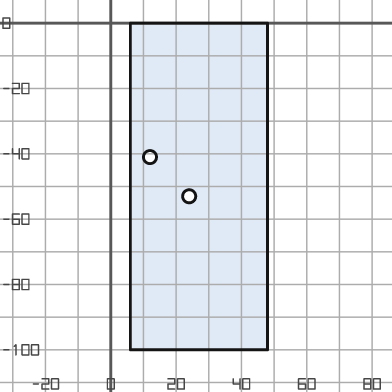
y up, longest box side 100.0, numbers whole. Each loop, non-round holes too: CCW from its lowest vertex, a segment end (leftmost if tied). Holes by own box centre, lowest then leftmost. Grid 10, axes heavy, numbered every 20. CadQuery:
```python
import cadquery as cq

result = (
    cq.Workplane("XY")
    .moveTo(6.0, -100.0)
    .lineTo(48.0, -100.0)
    .lineTo(48.0, 0.0)
    .lineTo(6.0, 0.0)
    .close()
    .moveTo(24.0, -53.0)
    .circle(2.0)
    .moveTo(12.0, -41.0)
    .circle(2.0)
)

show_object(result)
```